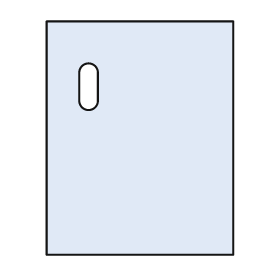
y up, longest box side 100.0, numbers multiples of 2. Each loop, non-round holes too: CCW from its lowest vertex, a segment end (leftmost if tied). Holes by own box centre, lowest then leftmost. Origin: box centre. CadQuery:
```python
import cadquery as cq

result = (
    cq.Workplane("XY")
    .moveTo(-40.0, -50.0)
    .lineTo(40.0, -50.0)
    .lineTo(40.0, 50.0)
    .lineTo(-40.0, 50.0)
    .close()
    .moveTo(-26.0, 16.0)
    .threePointArc((-22.0, 12.0), (-18.0, 16.0))
    .lineTo(-18.0, 28.0)
    .threePointArc((-22.0, 32.0), (-26.0, 28.0))
    .close()
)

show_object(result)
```